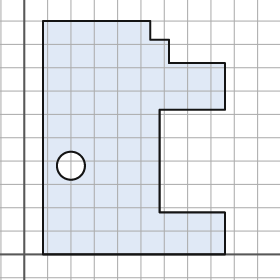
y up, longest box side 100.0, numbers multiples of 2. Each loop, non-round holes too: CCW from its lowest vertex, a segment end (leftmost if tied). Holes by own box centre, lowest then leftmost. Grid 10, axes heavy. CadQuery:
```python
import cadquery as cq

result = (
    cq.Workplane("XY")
    .moveTo(8.0, 0.0)
    .lineTo(86.0, 0.0)
    .lineTo(86.0, 18.0)
    .lineTo(58.0, 18.0)
    .lineTo(58.0, 62.0)
    .lineTo(86.0, 62.0)
    .lineTo(86.0, 82.0)
    .lineTo(62.0, 82.0)
    .lineTo(62.0, 92.0)
    .lineTo(54.0, 92.0)
    .lineTo(54.0, 100.0)
    .lineTo(8.0, 100.0)
    .close()
    .moveTo(20.0, 38.0)
    .circle(6.0)
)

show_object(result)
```